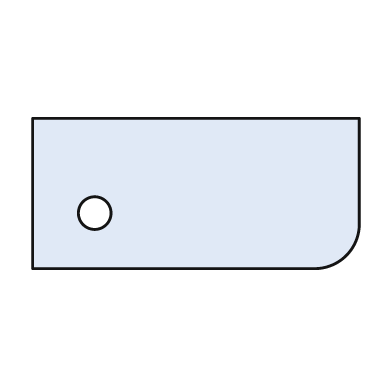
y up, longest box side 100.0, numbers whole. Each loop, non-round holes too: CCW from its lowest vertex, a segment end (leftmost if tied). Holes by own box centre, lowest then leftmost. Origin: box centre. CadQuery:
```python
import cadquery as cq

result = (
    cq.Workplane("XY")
    .moveTo(-50.0, -23.0)
    .lineTo(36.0, -23.0)
    .threePointArc((46.0, -19.0), (50.0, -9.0))
    .lineTo(50.0, 23.0)
    .lineTo(-50.0, 23.0)
    .close()
    .moveTo(-31.0, -6.0)
    .circle(5.0)
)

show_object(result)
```